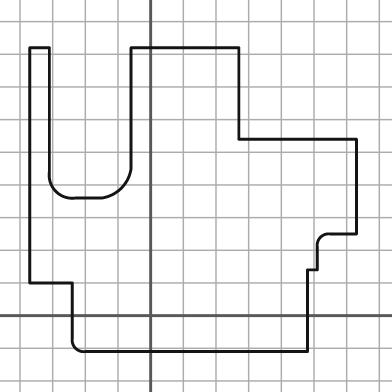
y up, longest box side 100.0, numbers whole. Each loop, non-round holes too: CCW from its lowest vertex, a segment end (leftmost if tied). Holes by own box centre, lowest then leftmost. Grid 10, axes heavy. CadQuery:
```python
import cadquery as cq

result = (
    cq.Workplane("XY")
    .moveTo(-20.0, -11.0)
    .lineTo(48.0, -11.0)
    .lineTo(48.0, 14.0)
    .lineTo(51.0, 14.0)
    .lineTo(51.0, 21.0)
    .threePointArc((52.0, 24.0), (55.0, 25.0))
    .lineTo(63.0, 25.0)
    .lineTo(63.0, 54.0)
    .lineTo(27.0, 54.0)
    .lineTo(27.0, 82.0)
    .lineTo(-6.0, 82.0)
    .lineTo(-6.0, 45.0)
    .threePointArc((-9.0, 39.0), (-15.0, 36.0))
    .lineTo(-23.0, 36.0)
    .threePointArc((-29.0, 38.0), (-31.0, 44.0))
    .lineTo(-31.0, 82.0)
    .lineTo(-37.0, 82.0)
    .lineTo(-37.0, 10.0)
    .lineTo(-24.0, 10.0)
    .lineTo(-24.0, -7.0)
    .threePointArc((-23.0, -10.0), (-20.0, -11.0))
    .close()
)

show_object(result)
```